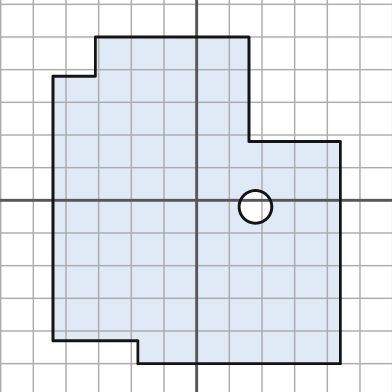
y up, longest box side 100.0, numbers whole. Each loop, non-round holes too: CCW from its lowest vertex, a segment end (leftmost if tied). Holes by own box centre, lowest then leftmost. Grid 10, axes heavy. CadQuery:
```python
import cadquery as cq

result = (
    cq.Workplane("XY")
    .moveTo(-18.0, -50.0)
    .lineTo(44.0, -50.0)
    .lineTo(44.0, 18.0)
    .lineTo(16.0, 18.0)
    .lineTo(16.0, 50.0)
    .lineTo(-31.0, 50.0)
    .lineTo(-31.0, 38.0)
    .lineTo(-44.0, 38.0)
    .lineTo(-44.0, -43.0)
    .lineTo(-18.0, -43.0)
    .close()
    .moveTo(18.0, -2.0)
    .circle(5.0)
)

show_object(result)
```